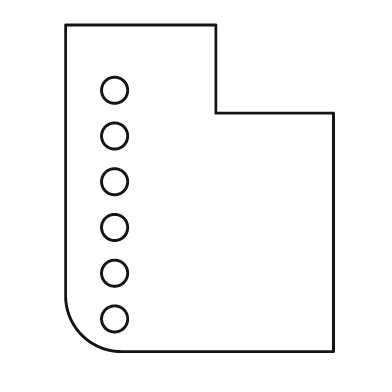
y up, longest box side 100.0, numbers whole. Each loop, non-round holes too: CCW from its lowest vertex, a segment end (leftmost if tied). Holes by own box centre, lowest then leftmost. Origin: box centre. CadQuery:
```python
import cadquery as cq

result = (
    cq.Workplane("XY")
    .moveTo(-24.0, -50.0)
    .lineTo(41.0, -50.0)
    .lineTo(41.0, 23.0)
    .lineTo(5.0, 23.0)
    .lineTo(5.0, 50.0)
    .lineTo(-41.0, 50.0)
    .lineTo(-41.0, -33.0)
    .threePointArc((-36.0, -45.0), (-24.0, -50.0))
    .close()
    .moveTo(-26.0, -40.0)
    .circle(4.0)
    .moveTo(-26.0, -26.0)
    .circle(4.0)
    .moveTo(-26.0, -12.0)
    .circle(4.0)
    .moveTo(-26.0, 2.0)
    .circle(4.0)
    .moveTo(-26.0, 16.0)
    .circle(4.0)
    .moveTo(-26.0, 30.0)
    .circle(4.0)
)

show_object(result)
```